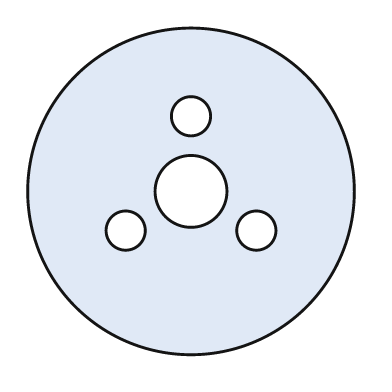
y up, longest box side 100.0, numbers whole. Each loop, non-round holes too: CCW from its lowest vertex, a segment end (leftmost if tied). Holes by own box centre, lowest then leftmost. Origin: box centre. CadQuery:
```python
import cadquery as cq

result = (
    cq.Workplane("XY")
    .moveTo(0.0, 0.0)
    .circle(50.0)
    .moveTo(-20.0, -12.0)
    .circle(6.0)
    .moveTo(20.0, -12.0)
    .circle(6.0)
    .moveTo(0.0, 0.0)
    .circle(11.0)
    .moveTo(0.0, 23.0)
    .circle(6.0)
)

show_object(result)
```